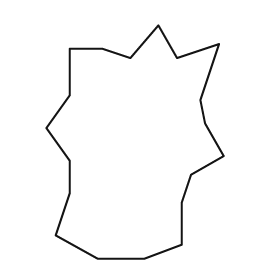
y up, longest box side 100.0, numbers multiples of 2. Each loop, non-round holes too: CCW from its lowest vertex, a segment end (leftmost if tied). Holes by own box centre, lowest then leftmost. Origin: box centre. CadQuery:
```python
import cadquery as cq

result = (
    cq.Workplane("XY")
    .moveTo(-16.0, -50.0)
    .lineTo(4.0, -50.0)
    .lineTo(20.0, -44.0)
    .lineTo(20.0, -26.0)
    .lineTo(24.0, -14.0)
    .lineTo(38.0, -6.0)
    .lineTo(30.0, 8.0)
    .lineTo(28.0, 18.0)
    .lineTo(36.0, 42.0)
    .lineTo(18.0, 36.0)
    .lineTo(10.0, 50.0)
    .lineTo(-2.0, 36.0)
    .lineTo(-14.0, 40.0)
    .lineTo(-28.0, 40.0)
    .lineTo(-28.0, 20.0)
    .lineTo(-38.0, 6.0)
    .lineTo(-28.0, -8.0)
    .lineTo(-28.0, -22.0)
    .lineTo(-34.0, -40.0)
    .close()
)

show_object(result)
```